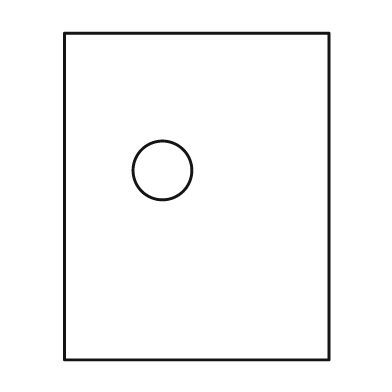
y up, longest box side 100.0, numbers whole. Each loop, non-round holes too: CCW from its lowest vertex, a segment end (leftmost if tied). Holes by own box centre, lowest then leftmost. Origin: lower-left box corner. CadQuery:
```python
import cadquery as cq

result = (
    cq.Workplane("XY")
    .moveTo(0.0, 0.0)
    .lineTo(81.0, 0.0)
    .lineTo(81.0, 100.0)
    .lineTo(0.0, 100.0)
    .close()
    .moveTo(30.0, 58.0)
    .circle(9.0)
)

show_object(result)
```